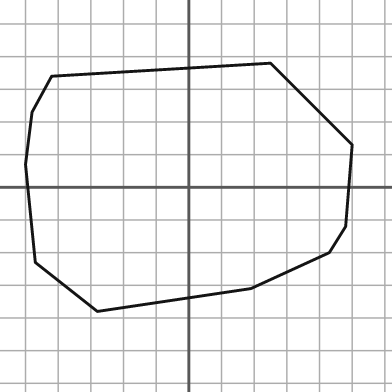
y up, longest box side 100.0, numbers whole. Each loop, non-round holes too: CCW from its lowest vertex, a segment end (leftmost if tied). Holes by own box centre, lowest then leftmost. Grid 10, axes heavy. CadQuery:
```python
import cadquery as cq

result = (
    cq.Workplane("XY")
    .moveTo(-28.0, -38.0)
    .lineTo(19.0, -31.0)
    .lineTo(43.0, -20.0)
    .lineTo(48.0, -12.0)
    .lineTo(50.0, 13.0)
    .lineTo(25.0, 38.0)
    .lineTo(-42.0, 34.0)
    .lineTo(-48.0, 23.0)
    .lineTo(-50.0, 7.0)
    .lineTo(-47.0, -23.0)
    .close()
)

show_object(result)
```